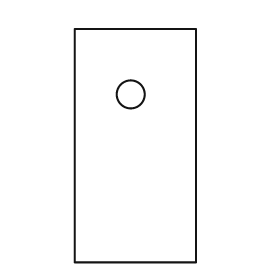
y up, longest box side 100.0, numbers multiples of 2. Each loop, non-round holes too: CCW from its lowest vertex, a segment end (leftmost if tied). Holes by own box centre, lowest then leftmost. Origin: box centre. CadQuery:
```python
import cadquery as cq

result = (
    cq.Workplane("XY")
    .moveTo(-26.0, -50.0)
    .lineTo(26.0, -50.0)
    .lineTo(26.0, 50.0)
    .lineTo(-26.0, 50.0)
    .close()
    .moveTo(-2.0, 22.0)
    .circle(6.0)
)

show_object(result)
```